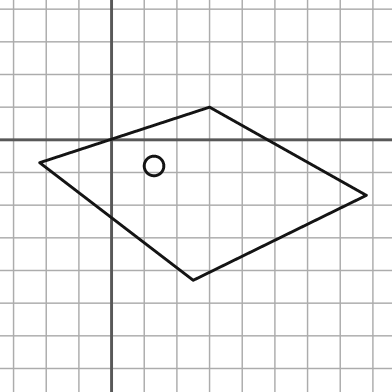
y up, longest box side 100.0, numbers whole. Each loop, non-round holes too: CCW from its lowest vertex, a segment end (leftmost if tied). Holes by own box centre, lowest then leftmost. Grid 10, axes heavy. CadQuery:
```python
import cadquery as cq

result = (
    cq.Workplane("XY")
    .moveTo(25.0, -43.0)
    .lineTo(78.0, -17.0)
    .lineTo(30.0, 10.0)
    .lineTo(-22.0, -7.0)
    .close()
    .moveTo(13.0, -8.0)
    .circle(3.0)
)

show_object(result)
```